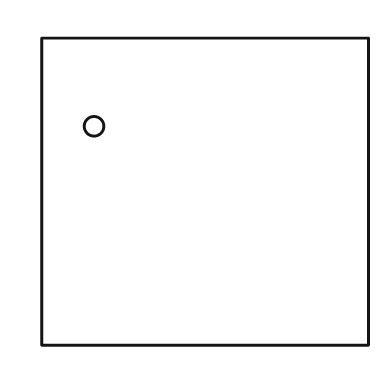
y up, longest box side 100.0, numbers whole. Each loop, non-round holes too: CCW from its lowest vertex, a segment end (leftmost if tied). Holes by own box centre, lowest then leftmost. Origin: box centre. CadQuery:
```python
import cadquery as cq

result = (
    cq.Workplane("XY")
    .moveTo(-50.0, -47.0)
    .lineTo(50.0, -47.0)
    .lineTo(50.0, 47.0)
    .lineTo(-50.0, 47.0)
    .close()
    .moveTo(-34.0, 20.0)
    .circle(3.0)
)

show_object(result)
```